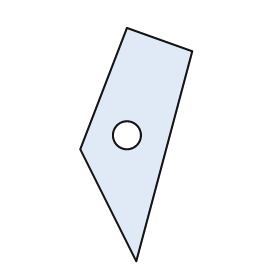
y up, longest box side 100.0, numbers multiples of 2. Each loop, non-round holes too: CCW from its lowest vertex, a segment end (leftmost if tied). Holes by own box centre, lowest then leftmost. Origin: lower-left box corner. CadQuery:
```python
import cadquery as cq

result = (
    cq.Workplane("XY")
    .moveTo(24.0, 0.0)
    .lineTo(48.0, 90.0)
    .lineTo(20.0, 100.0)
    .lineTo(0.0, 48.0)
    .close()
    .moveTo(20.0, 54.0)
    .circle(6.0)
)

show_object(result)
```